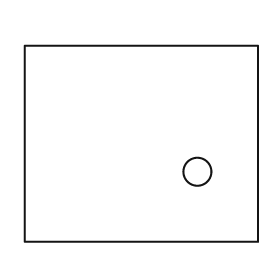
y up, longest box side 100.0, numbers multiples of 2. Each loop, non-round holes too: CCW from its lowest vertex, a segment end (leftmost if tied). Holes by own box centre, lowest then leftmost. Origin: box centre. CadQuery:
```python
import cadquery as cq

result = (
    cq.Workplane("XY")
    .moveTo(-50.0, -42.0)
    .lineTo(50.0, -42.0)
    .lineTo(50.0, 42.0)
    .lineTo(-50.0, 42.0)
    .close()
    .moveTo(24.0, -12.0)
    .circle(6.0)
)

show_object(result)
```